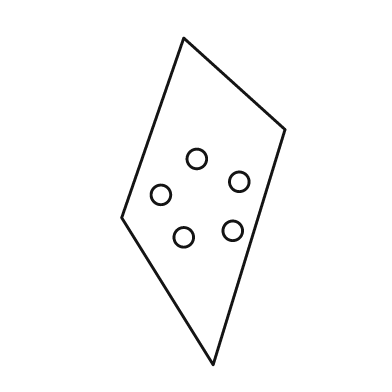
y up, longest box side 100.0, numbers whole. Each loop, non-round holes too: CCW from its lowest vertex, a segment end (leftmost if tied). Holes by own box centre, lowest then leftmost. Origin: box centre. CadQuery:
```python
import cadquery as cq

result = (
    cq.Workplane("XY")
    .moveTo(3.0, -50.0)
    .lineTo(25.0, 22.0)
    .lineTo(-6.0, 50.0)
    .lineTo(-25.0, -5.0)
    .close()
    .moveTo(-6.0, -11.0)
    .circle(3.0)
    .moveTo(9.0, -9.0)
    .circle(3.0)
    .moveTo(-13.0, 2.0)
    .circle(3.0)
    .moveTo(11.0, 6.0)
    .circle(3.0)
    .moveTo(-2.0, 13.0)
    .circle(3.0)
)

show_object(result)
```